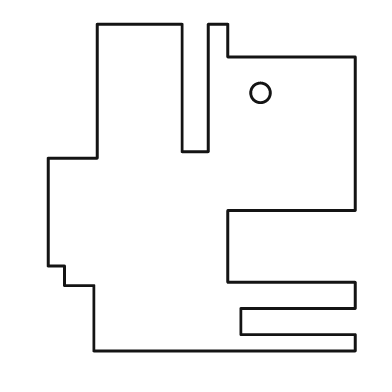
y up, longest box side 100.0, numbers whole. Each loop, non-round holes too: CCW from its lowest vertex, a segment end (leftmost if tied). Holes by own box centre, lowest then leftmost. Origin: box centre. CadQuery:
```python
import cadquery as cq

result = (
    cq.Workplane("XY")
    .moveTo(-33.0, -50.0)
    .lineTo(47.0, -50.0)
    .lineTo(47.0, -45.0)
    .lineTo(12.0, -45.0)
    .lineTo(12.0, -37.0)
    .lineTo(47.0, -37.0)
    .lineTo(47.0, -29.0)
    .lineTo(8.0, -29.0)
    .lineTo(8.0, -7.0)
    .lineTo(47.0, -7.0)
    .lineTo(47.0, 40.0)
    .lineTo(8.0, 40.0)
    .lineTo(8.0, 50.0)
    .lineTo(2.0, 50.0)
    .lineTo(2.0, 11.0)
    .lineTo(-6.0, 11.0)
    .lineTo(-6.0, 50.0)
    .lineTo(-32.0, 50.0)
    .lineTo(-32.0, 9.0)
    .lineTo(-47.0, 9.0)
    .lineTo(-47.0, -24.0)
    .lineTo(-42.0, -24.0)
    .lineTo(-42.0, -30.0)
    .lineTo(-33.0, -30.0)
    .close()
    .moveTo(18.0, 29.0)
    .circle(3.0)
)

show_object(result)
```